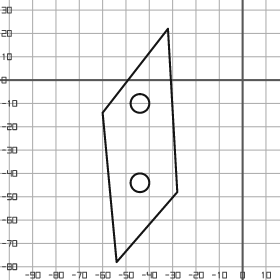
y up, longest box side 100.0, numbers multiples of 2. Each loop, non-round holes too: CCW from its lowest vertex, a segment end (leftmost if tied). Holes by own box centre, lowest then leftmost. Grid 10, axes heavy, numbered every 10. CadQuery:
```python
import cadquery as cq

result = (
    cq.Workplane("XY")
    .moveTo(-54.0, -78.0)
    .lineTo(-28.0, -48.0)
    .lineTo(-32.0, 22.0)
    .lineTo(-60.0, -14.0)
    .close()
    .moveTo(-44.0, -44.0)
    .circle(4.0)
    .moveTo(-44.0, -10.0)
    .circle(4.0)
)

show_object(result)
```